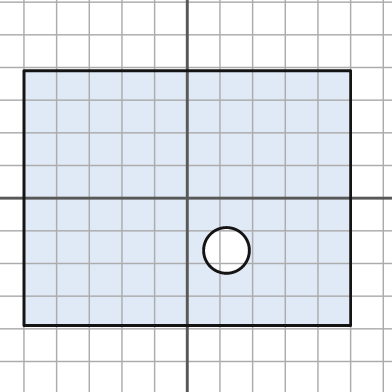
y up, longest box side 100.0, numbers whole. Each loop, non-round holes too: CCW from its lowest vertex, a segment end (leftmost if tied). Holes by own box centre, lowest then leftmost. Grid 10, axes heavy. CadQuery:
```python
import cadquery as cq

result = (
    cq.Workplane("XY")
    .moveTo(-50.0, -39.0)
    .lineTo(50.0, -39.0)
    .lineTo(50.0, 39.0)
    .lineTo(-50.0, 39.0)
    .close()
    .moveTo(12.0, -16.0)
    .circle(7.0)
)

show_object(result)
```